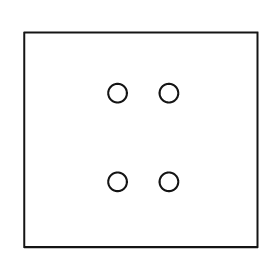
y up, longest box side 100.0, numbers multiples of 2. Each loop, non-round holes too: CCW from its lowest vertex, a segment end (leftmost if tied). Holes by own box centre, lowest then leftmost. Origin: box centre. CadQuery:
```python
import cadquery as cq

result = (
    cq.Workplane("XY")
    .moveTo(-50.0, -46.0)
    .lineTo(50.0, -46.0)
    .lineTo(50.0, 46.0)
    .lineTo(-50.0, 46.0)
    .close()
    .moveTo(-10.0, -18.0)
    .circle(4.0)
    .moveTo(12.0, -18.0)
    .circle(4.0)
    .moveTo(-10.0, 20.0)
    .circle(4.0)
    .moveTo(12.0, 20.0)
    .circle(4.0)
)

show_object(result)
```